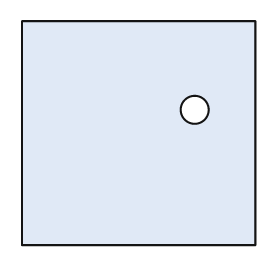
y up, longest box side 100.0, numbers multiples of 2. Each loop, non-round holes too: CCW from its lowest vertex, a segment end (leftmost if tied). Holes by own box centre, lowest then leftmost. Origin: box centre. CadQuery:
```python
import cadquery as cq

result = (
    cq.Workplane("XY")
    .moveTo(-50.0, -48.0)
    .lineTo(50.0, -48.0)
    .lineTo(50.0, 48.0)
    .lineTo(-50.0, 48.0)
    .close()
    .moveTo(24.0, 10.0)
    .circle(6.0)
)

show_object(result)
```